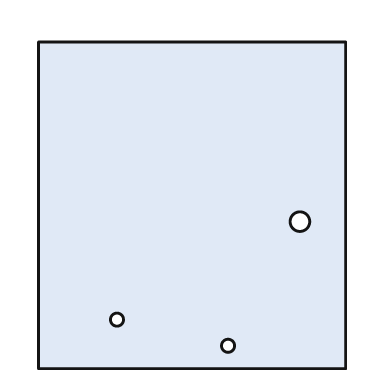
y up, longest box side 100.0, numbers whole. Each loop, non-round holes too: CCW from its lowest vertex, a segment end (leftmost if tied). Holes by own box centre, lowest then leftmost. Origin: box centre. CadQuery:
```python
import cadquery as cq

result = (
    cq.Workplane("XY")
    .moveTo(-47.0, -50.0)
    .lineTo(47.0, -50.0)
    .lineTo(47.0, 50.0)
    .lineTo(-47.0, 50.0)
    .close()
    .moveTo(11.0, -43.0)
    .circle(2.0)
    .moveTo(-23.0, -35.0)
    .circle(2.0)
    .moveTo(33.0, -5.0)
    .circle(3.0)
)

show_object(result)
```